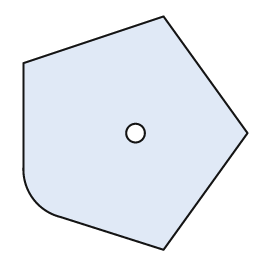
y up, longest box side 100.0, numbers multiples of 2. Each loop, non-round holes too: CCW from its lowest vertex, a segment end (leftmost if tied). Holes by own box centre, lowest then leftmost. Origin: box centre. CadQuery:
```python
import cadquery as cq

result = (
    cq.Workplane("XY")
    .moveTo(12.0, -50.0)
    .lineTo(48.0, 0.0)
    .lineTo(12.0, 50.0)
    .lineTo(-48.0, 30.0)
    .lineTo(-48.0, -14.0)
    .threePointArc((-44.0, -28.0), (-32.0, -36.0))
    .close()
    .moveTo(0.0, 0.0)
    .circle(4.0)
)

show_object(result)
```